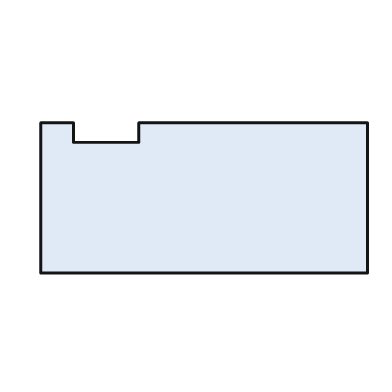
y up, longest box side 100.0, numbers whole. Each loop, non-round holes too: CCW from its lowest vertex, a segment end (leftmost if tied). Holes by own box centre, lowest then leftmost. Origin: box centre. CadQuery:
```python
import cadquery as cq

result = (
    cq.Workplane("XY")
    .moveTo(-50.0, -23.0)
    .lineTo(50.0, -23.0)
    .lineTo(50.0, 23.0)
    .lineTo(-20.0, 23.0)
    .lineTo(-20.0, 17.0)
    .lineTo(-40.0, 17.0)
    .lineTo(-40.0, 23.0)
    .lineTo(-50.0, 23.0)
    .close()
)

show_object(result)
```